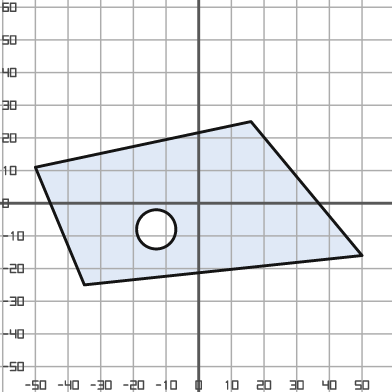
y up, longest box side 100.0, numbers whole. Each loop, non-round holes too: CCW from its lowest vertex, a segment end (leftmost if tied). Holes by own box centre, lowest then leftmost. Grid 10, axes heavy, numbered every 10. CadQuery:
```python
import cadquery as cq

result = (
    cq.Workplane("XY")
    .moveTo(-35.0, -25.0)
    .lineTo(50.0, -16.0)
    .lineTo(16.0, 25.0)
    .lineTo(-50.0, 11.0)
    .close()
    .moveTo(-13.0, -8.0)
    .circle(6.0)
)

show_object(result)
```